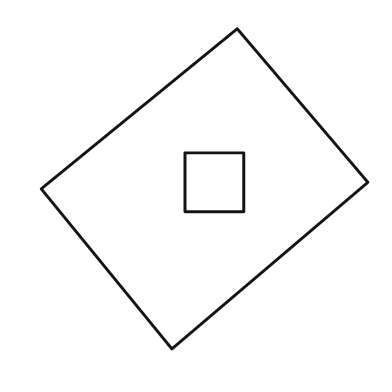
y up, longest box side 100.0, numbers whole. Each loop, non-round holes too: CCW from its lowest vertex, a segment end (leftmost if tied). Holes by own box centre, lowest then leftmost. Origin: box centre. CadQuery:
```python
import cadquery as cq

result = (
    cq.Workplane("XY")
    .moveTo(-10.0, -49.0)
    .lineTo(50.0, 2.0)
    .lineTo(10.0, 49.0)
    .lineTo(-50.0, 0.0)
    .close()
    .moveTo(-6.0, -7.0)
    .lineTo(12.0, -7.0)
    .lineTo(12.0, 11.0)
    .lineTo(-6.0, 11.0)
    .close()
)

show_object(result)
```